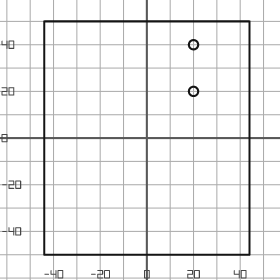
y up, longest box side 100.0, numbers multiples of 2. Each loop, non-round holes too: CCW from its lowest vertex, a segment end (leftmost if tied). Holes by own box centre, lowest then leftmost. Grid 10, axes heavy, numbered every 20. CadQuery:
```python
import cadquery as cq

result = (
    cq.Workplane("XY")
    .moveTo(-44.0, -50.0)
    .lineTo(44.0, -50.0)
    .lineTo(44.0, 50.0)
    .lineTo(-44.0, 50.0)
    .close()
    .moveTo(20.0, 20.0)
    .circle(2.0)
    .moveTo(20.0, 40.0)
    .circle(2.0)
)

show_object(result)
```